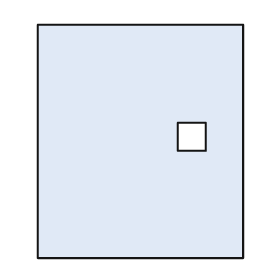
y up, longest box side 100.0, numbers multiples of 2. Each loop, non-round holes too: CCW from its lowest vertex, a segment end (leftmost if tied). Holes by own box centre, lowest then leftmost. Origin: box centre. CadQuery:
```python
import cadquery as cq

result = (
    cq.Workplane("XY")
    .moveTo(-44.0, -50.0)
    .lineTo(44.0, -50.0)
    .lineTo(44.0, 50.0)
    .lineTo(-44.0, 50.0)
    .close()
    .moveTo(16.0, -4.0)
    .lineTo(28.0, -4.0)
    .lineTo(28.0, 8.0)
    .lineTo(16.0, 8.0)
    .close()
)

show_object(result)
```